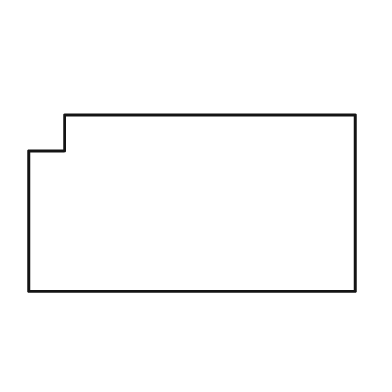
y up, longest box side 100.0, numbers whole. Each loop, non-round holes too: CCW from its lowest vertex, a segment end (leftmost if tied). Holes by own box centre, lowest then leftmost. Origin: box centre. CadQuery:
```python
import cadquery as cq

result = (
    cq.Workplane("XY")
    .moveTo(-50.0, -27.0)
    .lineTo(50.0, -27.0)
    .lineTo(50.0, 27.0)
    .lineTo(-39.0, 27.0)
    .lineTo(-39.0, 16.0)
    .lineTo(-50.0, 16.0)
    .close()
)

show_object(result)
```